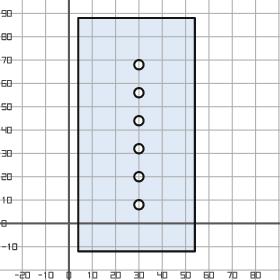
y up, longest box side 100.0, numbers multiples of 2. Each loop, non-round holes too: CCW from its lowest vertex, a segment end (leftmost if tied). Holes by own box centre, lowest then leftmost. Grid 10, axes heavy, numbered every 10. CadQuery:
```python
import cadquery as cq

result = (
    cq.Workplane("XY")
    .moveTo(4.0, -12.0)
    .lineTo(54.0, -12.0)
    .lineTo(54.0, 88.0)
    .lineTo(4.0, 88.0)
    .close()
    .moveTo(30.0, 8.0)
    .circle(2.0)
    .moveTo(30.0, 20.0)
    .circle(2.0)
    .moveTo(30.0, 32.0)
    .circle(2.0)
    .moveTo(30.0, 44.0)
    .circle(2.0)
    .moveTo(30.0, 56.0)
    .circle(2.0)
    .moveTo(30.0, 68.0)
    .circle(2.0)
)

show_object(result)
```